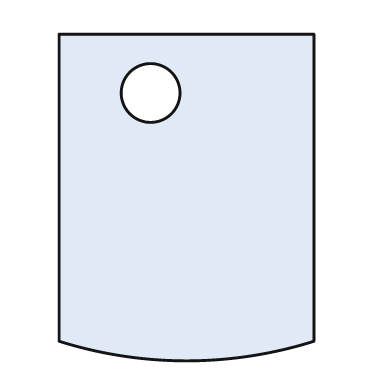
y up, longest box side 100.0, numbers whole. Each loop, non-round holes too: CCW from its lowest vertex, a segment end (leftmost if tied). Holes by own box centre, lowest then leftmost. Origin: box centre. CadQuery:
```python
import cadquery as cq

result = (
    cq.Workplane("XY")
    .moveTo(-39.0, -44.0)
    .threePointArc((0.0, -50.0), (39.0, -44.0))
    .lineTo(39.0, 50.0)
    .lineTo(-39.0, 50.0)
    .close()
    .moveTo(-11.0, 32.0)
    .circle(9.0)
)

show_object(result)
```